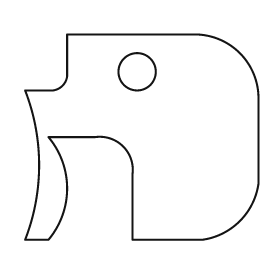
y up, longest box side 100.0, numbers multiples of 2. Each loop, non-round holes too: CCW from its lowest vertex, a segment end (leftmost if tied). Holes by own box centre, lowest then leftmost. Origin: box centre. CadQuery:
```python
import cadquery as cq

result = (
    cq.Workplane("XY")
    .moveTo(-50.0, -44.0)
    .lineTo(-40.0, -44.0)
    .threePointArc((-32.0, -22.0), (-40.0, 0.0))
    .lineTo(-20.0, 0.0)
    .threePointArc((-8.0, -4.0), (-4.0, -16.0))
    .lineTo(-4.0, -44.0)
    .lineTo(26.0, -44.0)
    .threePointArc((42.0, -36.0), (50.0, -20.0))
    .lineTo(50.0, 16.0)
    .threePointArc((42.0, 36.0), (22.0, 44.0))
    .lineTo(-32.0, 44.0)
    .lineTo(-32.0, 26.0)
    .threePointArc((-34.0, 22.0), (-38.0, 20.0))
    .lineTo(-50.0, 20.0)
    .threePointArc((-44.0, -12.0), (-50.0, -44.0))
    .close()
    .moveTo(-2.0, 28.0)
    .circle(8.0)
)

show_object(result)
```